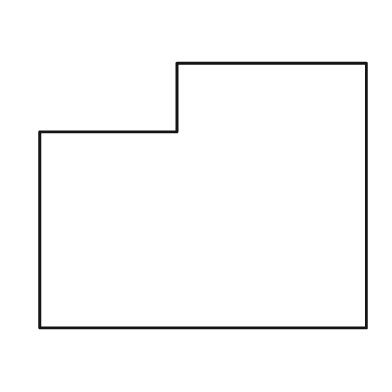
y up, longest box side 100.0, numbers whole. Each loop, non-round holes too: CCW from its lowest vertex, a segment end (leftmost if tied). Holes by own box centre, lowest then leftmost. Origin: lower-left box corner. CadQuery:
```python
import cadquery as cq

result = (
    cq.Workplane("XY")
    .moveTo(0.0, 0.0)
    .lineTo(100.0, 0.0)
    .lineTo(100.0, 81.0)
    .lineTo(42.0, 81.0)
    .lineTo(42.0, 60.0)
    .lineTo(0.0, 60.0)
    .close()
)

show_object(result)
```